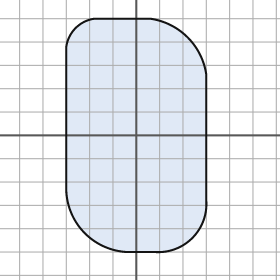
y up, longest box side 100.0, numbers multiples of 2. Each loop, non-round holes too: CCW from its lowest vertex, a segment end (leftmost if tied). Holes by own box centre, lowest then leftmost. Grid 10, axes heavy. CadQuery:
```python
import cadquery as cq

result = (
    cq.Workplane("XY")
    .moveTo(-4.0, -50.0)
    .lineTo(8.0, -50.0)
    .threePointArc((24.0, -44.0), (30.0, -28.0))
    .lineTo(30.0, 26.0)
    .threePointArc((22.0, 42.0), (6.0, 50.0))
    .lineTo(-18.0, 50.0)
    .threePointArc((-26.0, 46.0), (-30.0, 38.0))
    .lineTo(-30.0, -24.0)
    .threePointArc((-22.0, -42.0), (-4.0, -50.0))
    .close()
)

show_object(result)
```